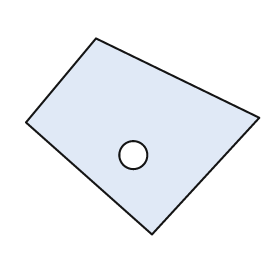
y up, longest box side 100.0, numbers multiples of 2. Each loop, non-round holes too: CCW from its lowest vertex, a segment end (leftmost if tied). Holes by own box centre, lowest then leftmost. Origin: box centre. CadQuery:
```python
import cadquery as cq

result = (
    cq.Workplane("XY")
    .moveTo(4.0, -42.0)
    .lineTo(50.0, 8.0)
    .lineTo(-20.0, 42.0)
    .lineTo(-50.0, 6.0)
    .close()
    .moveTo(-4.0, -8.0)
    .circle(6.0)
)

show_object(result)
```